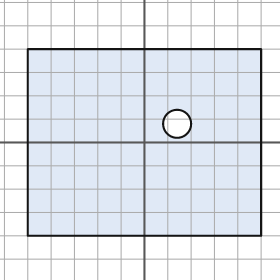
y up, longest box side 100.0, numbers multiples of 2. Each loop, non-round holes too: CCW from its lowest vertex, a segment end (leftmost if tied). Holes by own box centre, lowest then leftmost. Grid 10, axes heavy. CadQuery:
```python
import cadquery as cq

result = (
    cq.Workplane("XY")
    .moveTo(-50.0, -40.0)
    .lineTo(50.0, -40.0)
    .lineTo(50.0, 40.0)
    .lineTo(-50.0, 40.0)
    .close()
    .moveTo(14.0, 8.0)
    .circle(6.0)
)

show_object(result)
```